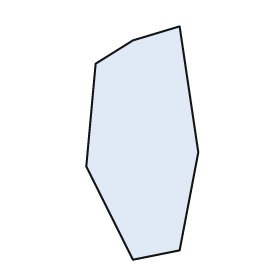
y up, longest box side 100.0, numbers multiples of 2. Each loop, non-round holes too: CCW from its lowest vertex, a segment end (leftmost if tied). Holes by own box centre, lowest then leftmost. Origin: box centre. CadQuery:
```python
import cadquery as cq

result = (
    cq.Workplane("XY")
    .moveTo(-4.0, -50.0)
    .lineTo(16.0, -46.0)
    .lineTo(24.0, -4.0)
    .lineTo(16.0, 50.0)
    .lineTo(-4.0, 44.0)
    .lineTo(-20.0, 34.0)
    .lineTo(-24.0, -10.0)
    .close()
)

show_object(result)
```